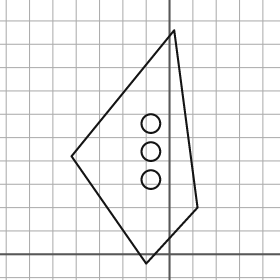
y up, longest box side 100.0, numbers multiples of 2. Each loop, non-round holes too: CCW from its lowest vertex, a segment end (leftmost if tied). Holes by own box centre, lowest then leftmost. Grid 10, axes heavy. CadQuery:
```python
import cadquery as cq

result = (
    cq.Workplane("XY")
    .moveTo(-10.0, -4.0)
    .lineTo(12.0, 20.0)
    .lineTo(2.0, 96.0)
    .lineTo(-42.0, 42.0)
    .close()
    .moveTo(-8.0, 32.0)
    .circle(4.0)
    .moveTo(-8.0, 44.0)
    .circle(4.0)
    .moveTo(-8.0, 56.0)
    .circle(4.0)
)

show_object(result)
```